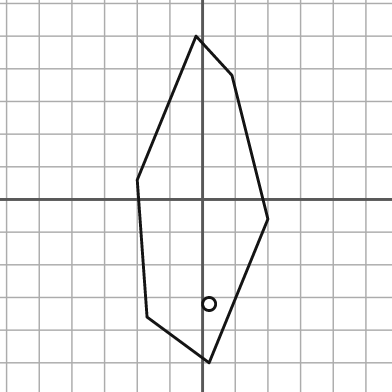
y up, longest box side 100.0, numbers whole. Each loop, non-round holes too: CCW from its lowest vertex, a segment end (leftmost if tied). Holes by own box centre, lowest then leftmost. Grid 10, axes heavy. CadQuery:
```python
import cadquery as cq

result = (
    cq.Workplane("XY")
    .moveTo(2.0, -50.0)
    .lineTo(20.0, -6.0)
    .lineTo(9.0, 38.0)
    .lineTo(-2.0, 50.0)
    .lineTo(-20.0, 6.0)
    .lineTo(-17.0, -36.0)
    .close()
    .moveTo(2.0, -32.0)
    .circle(2.0)
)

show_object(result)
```